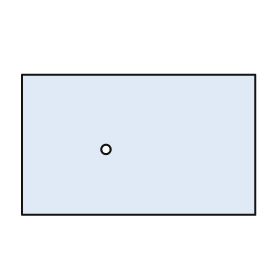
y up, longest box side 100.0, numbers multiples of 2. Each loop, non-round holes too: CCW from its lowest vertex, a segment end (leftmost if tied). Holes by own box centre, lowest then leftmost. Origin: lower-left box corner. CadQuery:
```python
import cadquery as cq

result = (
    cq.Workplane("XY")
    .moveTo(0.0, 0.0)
    .lineTo(100.0, 0.0)
    .lineTo(100.0, 60.0)
    .lineTo(0.0, 60.0)
    .close()
    .moveTo(36.0, 28.0)
    .circle(2.0)
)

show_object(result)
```